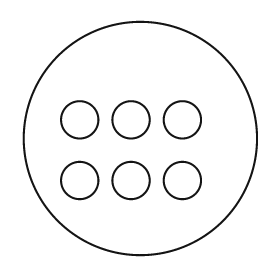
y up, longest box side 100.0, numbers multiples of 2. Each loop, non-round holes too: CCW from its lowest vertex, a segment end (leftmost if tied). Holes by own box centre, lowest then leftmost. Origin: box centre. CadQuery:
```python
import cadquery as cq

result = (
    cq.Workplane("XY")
    .moveTo(0.0, 0.0)
    .circle(50.0)
    .moveTo(-26.0, -18.0)
    .circle(8.0)
    .moveTo(-4.0, -18.0)
    .circle(8.0)
    .moveTo(18.0, -18.0)
    .circle(8.0)
    .moveTo(-26.0, 8.0)
    .circle(8.0)
    .moveTo(-4.0, 8.0)
    .circle(8.0)
    .moveTo(18.0, 8.0)
    .circle(8.0)
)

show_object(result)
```